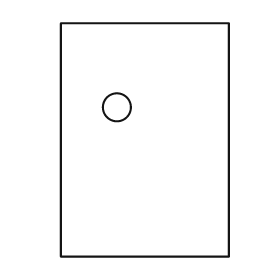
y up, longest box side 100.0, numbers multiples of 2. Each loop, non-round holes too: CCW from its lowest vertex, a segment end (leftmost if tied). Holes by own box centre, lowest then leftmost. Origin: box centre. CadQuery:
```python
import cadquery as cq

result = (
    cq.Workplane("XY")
    .moveTo(-36.0, -50.0)
    .lineTo(36.0, -50.0)
    .lineTo(36.0, 50.0)
    .lineTo(-36.0, 50.0)
    .close()
    .moveTo(-12.0, 14.0)
    .circle(6.0)
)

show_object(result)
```